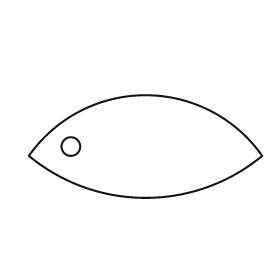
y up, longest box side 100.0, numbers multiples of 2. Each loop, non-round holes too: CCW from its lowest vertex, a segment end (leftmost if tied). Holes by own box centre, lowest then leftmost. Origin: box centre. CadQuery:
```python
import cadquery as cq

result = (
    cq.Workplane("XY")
    .moveTo(-50.0, -4.0)
    .threePointArc((0.0, -22.0), (50.0, -4.0))
    .threePointArc((0.0, 22.0), (-50.0, -4.0))
    .close()
    .moveTo(-32.0, 0.0)
    .circle(4.0)
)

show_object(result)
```